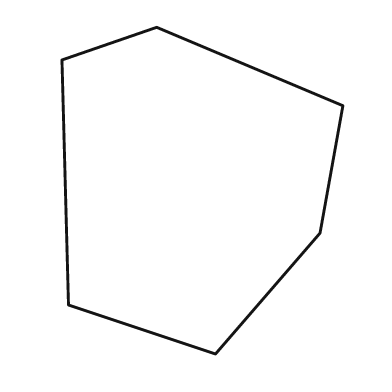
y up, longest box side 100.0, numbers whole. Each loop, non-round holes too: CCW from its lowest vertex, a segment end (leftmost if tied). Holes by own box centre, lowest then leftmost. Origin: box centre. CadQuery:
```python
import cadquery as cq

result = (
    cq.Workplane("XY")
    .moveTo(4.0, -50.0)
    .lineTo(36.0, -13.0)
    .lineTo(43.0, 26.0)
    .lineTo(-14.0, 50.0)
    .lineTo(-43.0, 40.0)
    .lineTo(-41.0, -35.0)
    .close()
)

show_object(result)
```